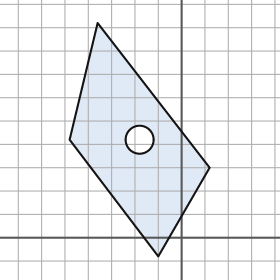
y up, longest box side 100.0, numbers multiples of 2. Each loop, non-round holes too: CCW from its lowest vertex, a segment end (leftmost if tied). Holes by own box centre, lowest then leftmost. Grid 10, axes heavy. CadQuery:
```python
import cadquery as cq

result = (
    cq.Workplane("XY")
    .moveTo(-10.0, -8.0)
    .lineTo(12.0, 30.0)
    .lineTo(-36.0, 92.0)
    .lineTo(-48.0, 42.0)
    .close()
    .moveTo(-18.0, 42.0)
    .circle(6.0)
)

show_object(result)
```